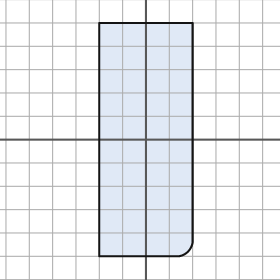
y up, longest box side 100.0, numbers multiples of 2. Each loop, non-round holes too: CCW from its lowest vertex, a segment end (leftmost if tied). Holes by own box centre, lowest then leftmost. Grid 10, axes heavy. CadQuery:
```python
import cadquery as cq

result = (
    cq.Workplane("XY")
    .moveTo(-20.0, -50.0)
    .lineTo(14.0, -50.0)
    .threePointArc((18.0, -48.0), (20.0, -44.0))
    .lineTo(20.0, 50.0)
    .lineTo(-20.0, 50.0)
    .close()
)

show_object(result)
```